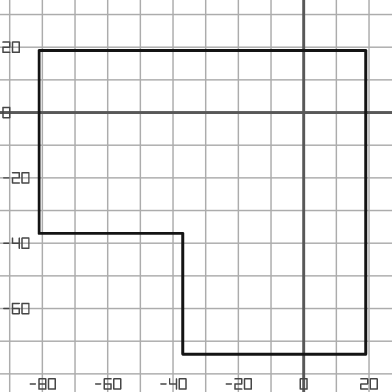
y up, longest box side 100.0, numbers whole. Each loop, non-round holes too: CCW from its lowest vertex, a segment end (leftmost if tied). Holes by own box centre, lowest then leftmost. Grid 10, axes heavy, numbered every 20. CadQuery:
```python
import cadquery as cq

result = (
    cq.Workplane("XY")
    .moveTo(-37.0, -74.0)
    .lineTo(19.0, -74.0)
    .lineTo(19.0, 19.0)
    .lineTo(-81.0, 19.0)
    .lineTo(-81.0, -37.0)
    .lineTo(-37.0, -37.0)
    .close()
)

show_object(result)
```